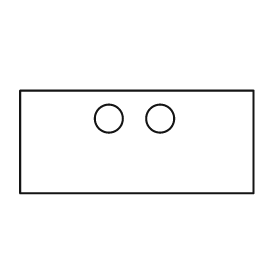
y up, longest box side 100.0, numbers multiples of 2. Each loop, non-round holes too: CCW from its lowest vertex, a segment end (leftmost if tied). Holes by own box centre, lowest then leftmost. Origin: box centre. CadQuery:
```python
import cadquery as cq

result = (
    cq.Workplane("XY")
    .moveTo(-50.0, -22.0)
    .lineTo(50.0, -22.0)
    .lineTo(50.0, 22.0)
    .lineTo(-50.0, 22.0)
    .close()
    .moveTo(-12.0, 10.0)
    .circle(6.0)
    .moveTo(10.0, 10.0)
    .circle(6.0)
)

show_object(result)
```